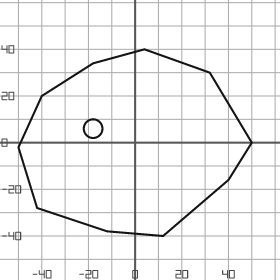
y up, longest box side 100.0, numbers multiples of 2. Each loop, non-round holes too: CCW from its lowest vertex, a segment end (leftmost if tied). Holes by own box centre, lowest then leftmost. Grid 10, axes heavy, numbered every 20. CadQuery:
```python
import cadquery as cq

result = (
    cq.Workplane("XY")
    .moveTo(12.0, -40.0)
    .lineTo(40.0, -16.0)
    .lineTo(50.0, 0.0)
    .lineTo(32.0, 30.0)
    .lineTo(4.0, 40.0)
    .lineTo(-18.0, 34.0)
    .lineTo(-40.0, 20.0)
    .lineTo(-50.0, -2.0)
    .lineTo(-42.0, -28.0)
    .lineTo(-12.0, -38.0)
    .close()
    .moveTo(-18.0, 6.0)
    .circle(4.0)
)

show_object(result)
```